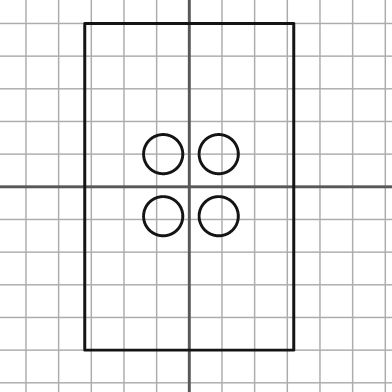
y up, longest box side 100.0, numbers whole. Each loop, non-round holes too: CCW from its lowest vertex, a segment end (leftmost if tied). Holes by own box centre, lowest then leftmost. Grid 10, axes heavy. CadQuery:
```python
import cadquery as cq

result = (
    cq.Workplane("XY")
    .moveTo(-32.0, -50.0)
    .lineTo(32.0, -50.0)
    .lineTo(32.0, 50.0)
    .lineTo(-32.0, 50.0)
    .close()
    .moveTo(-8.0, -9.0)
    .circle(6.0)
    .moveTo(9.0, -9.0)
    .circle(6.0)
    .moveTo(-8.0, 10.0)
    .circle(6.0)
    .moveTo(9.0, 10.0)
    .circle(6.0)
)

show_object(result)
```